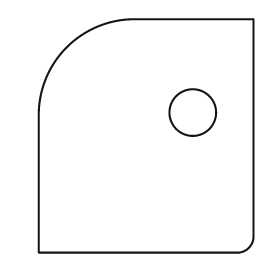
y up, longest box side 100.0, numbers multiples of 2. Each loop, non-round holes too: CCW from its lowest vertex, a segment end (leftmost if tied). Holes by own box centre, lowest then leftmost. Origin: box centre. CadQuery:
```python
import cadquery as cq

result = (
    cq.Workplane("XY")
    .moveTo(-46.0, -50.0)
    .lineTo(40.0, -50.0)
    .threePointArc((44.0, -48.0), (46.0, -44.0))
    .lineTo(46.0, 50.0)
    .lineTo(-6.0, 50.0)
    .threePointArc((-34.0, 38.0), (-46.0, 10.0))
    .close()
    .moveTo(20.0, 10.0)
    .circle(10.0)
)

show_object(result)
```